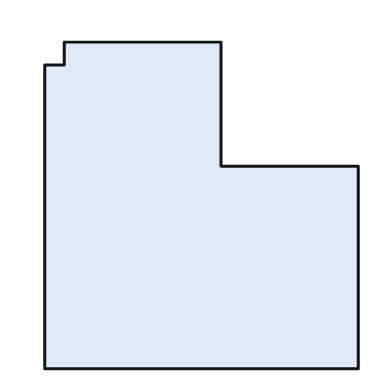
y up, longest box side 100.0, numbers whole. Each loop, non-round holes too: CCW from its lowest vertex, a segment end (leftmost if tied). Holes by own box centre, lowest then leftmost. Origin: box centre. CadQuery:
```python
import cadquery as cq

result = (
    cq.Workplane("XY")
    .moveTo(-48.0, -50.0)
    .lineTo(48.0, -50.0)
    .lineTo(48.0, 12.0)
    .lineTo(6.0, 12.0)
    .lineTo(6.0, 50.0)
    .lineTo(-42.0, 50.0)
    .lineTo(-42.0, 43.0)
    .lineTo(-48.0, 43.0)
    .close()
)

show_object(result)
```